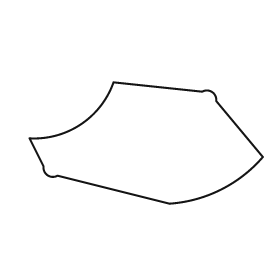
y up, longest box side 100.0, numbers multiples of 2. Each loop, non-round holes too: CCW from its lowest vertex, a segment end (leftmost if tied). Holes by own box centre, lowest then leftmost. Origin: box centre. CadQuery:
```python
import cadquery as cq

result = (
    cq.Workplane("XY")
    .moveTo(10.0, -26.0)
    .threePointArc((32.0, -20.0), (50.0, -6.0))
    .lineTo(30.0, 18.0)
    .threePointArc((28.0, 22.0), (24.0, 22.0))
    .lineTo(-14.0, 26.0)
    .threePointArc((-28.0, 8.0), (-50.0, 2.0))
    .lineTo(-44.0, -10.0)
    .threePointArc((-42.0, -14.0), (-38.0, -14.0))
    .close()
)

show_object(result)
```